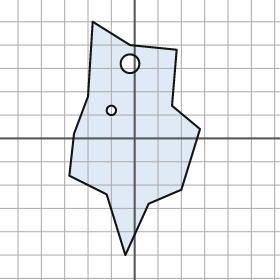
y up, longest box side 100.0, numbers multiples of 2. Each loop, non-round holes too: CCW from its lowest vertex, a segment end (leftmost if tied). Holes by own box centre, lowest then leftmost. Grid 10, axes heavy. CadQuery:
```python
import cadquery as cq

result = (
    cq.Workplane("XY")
    .moveTo(-4.0, -50.0)
    .lineTo(6.0, -28.0)
    .lineTo(20.0, -22.0)
    .lineTo(28.0, 4.0)
    .lineTo(16.0, 14.0)
    .lineTo(18.0, 38.0)
    .lineTo(-2.0, 40.0)
    .lineTo(-18.0, 50.0)
    .lineTo(-20.0, 18.0)
    .lineTo(-26.0, 2.0)
    .lineTo(-28.0, -16.0)
    .lineTo(-12.0, -24.0)
    .close()
    .moveTo(-10.0, 12.0)
    .circle(2.0)
    .moveTo(-2.0, 32.0)
    .circle(4.0)
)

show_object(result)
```